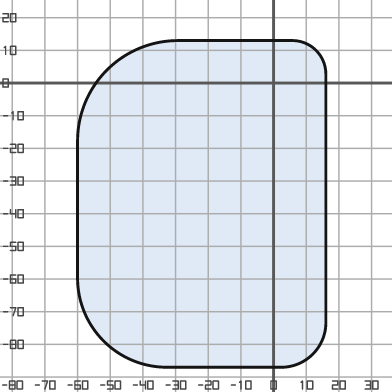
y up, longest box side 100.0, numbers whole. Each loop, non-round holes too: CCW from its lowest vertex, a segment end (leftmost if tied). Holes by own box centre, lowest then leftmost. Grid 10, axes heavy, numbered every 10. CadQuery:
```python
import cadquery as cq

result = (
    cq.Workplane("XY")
    .moveTo(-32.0, -87.0)
    .lineTo(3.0, -87.0)
    .threePointArc((12.0, -83.0), (16.0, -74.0))
    .lineTo(16.0, 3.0)
    .threePointArc((13.0, 10.0), (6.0, 13.0))
    .lineTo(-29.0, 13.0)
    .threePointArc((-51.0, 4.0), (-60.0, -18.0))
    .lineTo(-60.0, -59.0)
    .threePointArc((-52.0, -79.0), (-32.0, -87.0))
    .close()
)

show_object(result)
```